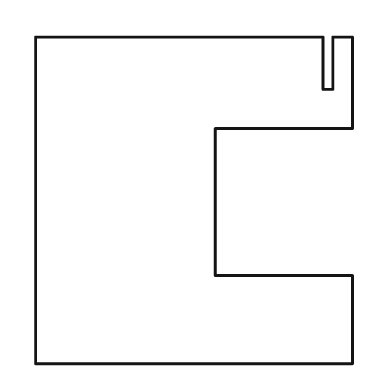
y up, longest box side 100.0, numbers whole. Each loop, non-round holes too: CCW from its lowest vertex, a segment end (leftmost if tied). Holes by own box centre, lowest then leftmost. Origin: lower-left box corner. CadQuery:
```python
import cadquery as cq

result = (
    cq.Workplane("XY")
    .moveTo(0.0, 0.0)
    .lineTo(97.0, 0.0)
    .lineTo(97.0, 27.0)
    .lineTo(55.0, 27.0)
    .lineTo(55.0, 72.0)
    .lineTo(97.0, 72.0)
    .lineTo(97.0, 100.0)
    .lineTo(91.0, 100.0)
    .lineTo(91.0, 84.0)
    .lineTo(88.0, 84.0)
    .lineTo(88.0, 100.0)
    .lineTo(0.0, 100.0)
    .close()
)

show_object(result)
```